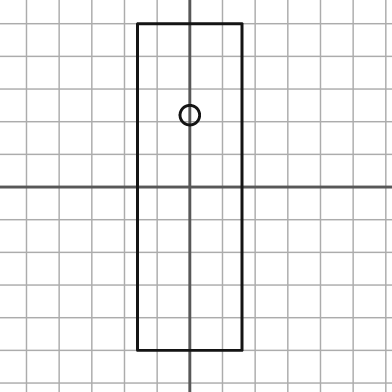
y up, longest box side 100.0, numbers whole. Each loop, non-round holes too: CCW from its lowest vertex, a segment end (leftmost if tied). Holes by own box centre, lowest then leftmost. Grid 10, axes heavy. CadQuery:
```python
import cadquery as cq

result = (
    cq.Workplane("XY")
    .moveTo(-16.0, -50.0)
    .lineTo(16.0, -50.0)
    .lineTo(16.0, 50.0)
    .lineTo(-16.0, 50.0)
    .close()
    .moveTo(0.0, 22.0)
    .circle(3.0)
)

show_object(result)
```